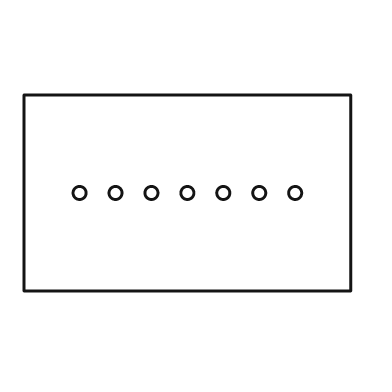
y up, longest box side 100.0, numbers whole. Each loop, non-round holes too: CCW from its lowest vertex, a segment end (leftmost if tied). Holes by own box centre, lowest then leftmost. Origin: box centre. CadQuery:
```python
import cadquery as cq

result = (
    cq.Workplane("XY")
    .moveTo(-50.0, -30.0)
    .lineTo(50.0, -30.0)
    .lineTo(50.0, 30.0)
    .lineTo(-50.0, 30.0)
    .close()
    .moveTo(-33.0, 0.0)
    .circle(2.0)
    .moveTo(-22.0, 0.0)
    .circle(2.0)
    .moveTo(-11.0, 0.0)
    .circle(2.0)
    .moveTo(0.0, 0.0)
    .circle(2.0)
    .moveTo(11.0, 0.0)
    .circle(2.0)
    .moveTo(22.0, 0.0)
    .circle(2.0)
    .moveTo(33.0, 0.0)
    .circle(2.0)
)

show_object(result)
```